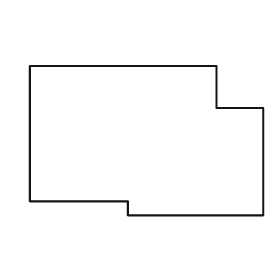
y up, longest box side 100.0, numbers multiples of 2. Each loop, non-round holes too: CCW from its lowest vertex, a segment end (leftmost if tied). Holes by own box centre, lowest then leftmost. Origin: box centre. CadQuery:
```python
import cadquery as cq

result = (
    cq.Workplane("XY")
    .moveTo(-8.0, -32.0)
    .lineTo(50.0, -32.0)
    .lineTo(50.0, 14.0)
    .lineTo(30.0, 14.0)
    .lineTo(30.0, 32.0)
    .lineTo(-50.0, 32.0)
    .lineTo(-50.0, -26.0)
    .lineTo(-8.0, -26.0)
    .close()
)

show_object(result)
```